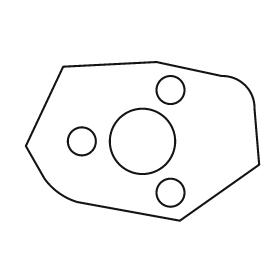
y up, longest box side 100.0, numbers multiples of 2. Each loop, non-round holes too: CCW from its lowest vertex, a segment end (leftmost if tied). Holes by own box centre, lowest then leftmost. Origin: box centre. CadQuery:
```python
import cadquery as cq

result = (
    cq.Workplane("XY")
    .moveTo(16.0, -34.0)
    .lineTo(50.0, -10.0)
    .lineTo(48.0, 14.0)
    .threePointArc((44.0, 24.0), (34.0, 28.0))
    .lineTo(6.0, 34.0)
    .lineTo(-34.0, 32.0)
    .lineTo(-50.0, -2.0)
    .lineTo(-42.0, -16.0)
    .threePointArc((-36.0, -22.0), (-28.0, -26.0))
    .close()
    .moveTo(12.0, -22.0)
    .circle(6.0)
    .moveTo(-26.0, 0.0)
    .circle(6.0)
    .moveTo(0.0, 0.0)
    .circle(14.0)
    .moveTo(12.0, 22.0)
    .circle(6.0)
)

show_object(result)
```